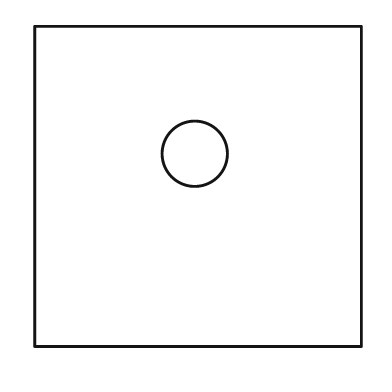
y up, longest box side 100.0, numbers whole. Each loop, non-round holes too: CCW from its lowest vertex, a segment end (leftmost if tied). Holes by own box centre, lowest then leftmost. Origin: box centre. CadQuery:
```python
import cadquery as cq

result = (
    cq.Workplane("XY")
    .moveTo(-50.0, -49.0)
    .lineTo(50.0, -49.0)
    .lineTo(50.0, 49.0)
    .lineTo(-50.0, 49.0)
    .close()
    .moveTo(-1.0, 10.0)
    .circle(10.0)
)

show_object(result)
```